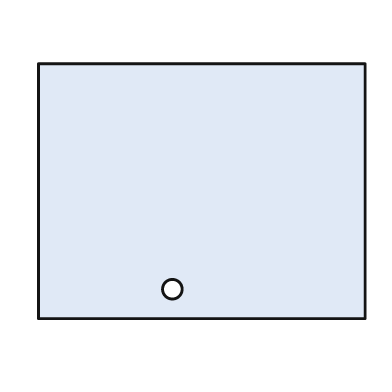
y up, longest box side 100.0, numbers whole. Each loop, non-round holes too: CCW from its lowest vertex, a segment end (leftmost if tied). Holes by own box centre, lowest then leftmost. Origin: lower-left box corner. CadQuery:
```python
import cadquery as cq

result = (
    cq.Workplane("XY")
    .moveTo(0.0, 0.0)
    .lineTo(100.0, 0.0)
    .lineTo(100.0, 78.0)
    .lineTo(0.0, 78.0)
    .close()
    .moveTo(41.0, 9.0)
    .circle(3.0)
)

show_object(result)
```